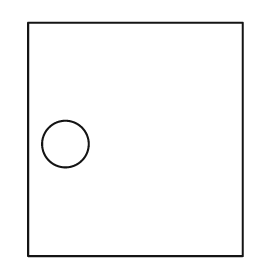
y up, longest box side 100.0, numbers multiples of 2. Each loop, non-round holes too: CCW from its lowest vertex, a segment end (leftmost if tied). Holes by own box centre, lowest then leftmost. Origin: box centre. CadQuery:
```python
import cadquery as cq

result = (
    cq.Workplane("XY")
    .moveTo(-46.0, -50.0)
    .lineTo(46.0, -50.0)
    .lineTo(46.0, 50.0)
    .lineTo(-46.0, 50.0)
    .close()
    .moveTo(-30.0, -2.0)
    .circle(10.0)
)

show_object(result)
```